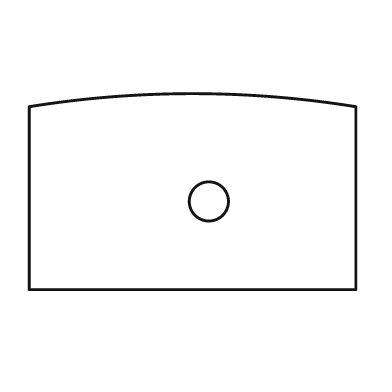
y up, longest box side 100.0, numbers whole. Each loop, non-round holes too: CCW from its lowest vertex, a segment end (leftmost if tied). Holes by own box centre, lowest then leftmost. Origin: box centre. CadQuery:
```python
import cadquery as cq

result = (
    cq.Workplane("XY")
    .moveTo(-50.0, -30.0)
    .lineTo(50.0, -30.0)
    .lineTo(50.0, 26.0)
    .threePointArc((0.0, 30.0), (-50.0, 26.0))
    .close()
    .moveTo(5.0, -3.0)
    .circle(6.0)
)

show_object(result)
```